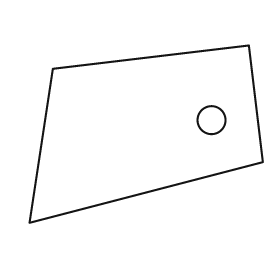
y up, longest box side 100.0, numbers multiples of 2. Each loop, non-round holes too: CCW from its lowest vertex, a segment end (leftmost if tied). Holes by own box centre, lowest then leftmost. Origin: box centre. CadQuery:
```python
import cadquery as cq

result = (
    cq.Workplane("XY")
    .moveTo(-50.0, -38.0)
    .lineTo(50.0, -12.0)
    .lineTo(44.0, 38.0)
    .lineTo(-40.0, 28.0)
    .close()
    .moveTo(28.0, 6.0)
    .circle(6.0)
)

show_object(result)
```